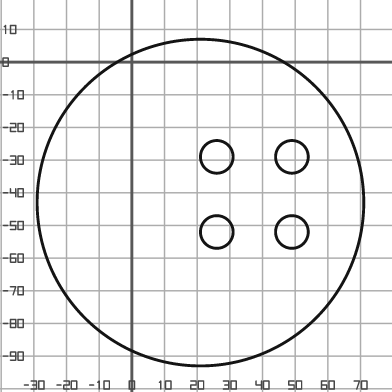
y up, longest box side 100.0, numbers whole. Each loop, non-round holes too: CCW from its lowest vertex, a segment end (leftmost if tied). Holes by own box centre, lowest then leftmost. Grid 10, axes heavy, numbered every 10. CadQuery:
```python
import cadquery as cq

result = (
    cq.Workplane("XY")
    .moveTo(21.0, -43.0)
    .circle(50.0)
    .moveTo(26.0, -52.0)
    .circle(5.0)
    .moveTo(49.0, -52.0)
    .circle(5.0)
    .moveTo(26.0, -29.0)
    .circle(5.0)
    .moveTo(49.0, -29.0)
    .circle(5.0)
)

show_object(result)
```